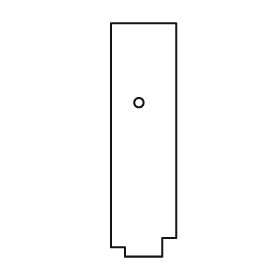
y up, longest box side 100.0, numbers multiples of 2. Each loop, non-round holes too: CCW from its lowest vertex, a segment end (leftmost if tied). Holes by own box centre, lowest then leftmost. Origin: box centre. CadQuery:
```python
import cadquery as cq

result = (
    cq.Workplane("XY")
    .moveTo(-8.0, -50.0)
    .lineTo(8.0, -50.0)
    .lineTo(8.0, -42.0)
    .lineTo(14.0, -42.0)
    .lineTo(14.0, 50.0)
    .lineTo(-14.0, 50.0)
    .lineTo(-14.0, -46.0)
    .lineTo(-8.0, -46.0)
    .close()
    .moveTo(-2.0, 16.0)
    .circle(2.0)
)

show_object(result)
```